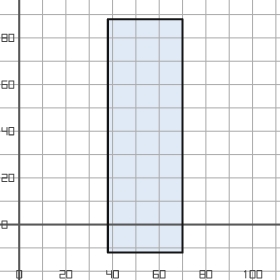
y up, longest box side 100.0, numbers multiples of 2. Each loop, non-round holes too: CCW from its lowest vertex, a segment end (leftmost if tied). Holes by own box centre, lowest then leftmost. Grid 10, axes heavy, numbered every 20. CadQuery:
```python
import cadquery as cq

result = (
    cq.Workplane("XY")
    .moveTo(38.0, -12.0)
    .lineTo(70.0, -12.0)
    .lineTo(70.0, 88.0)
    .lineTo(38.0, 88.0)
    .close()
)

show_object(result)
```